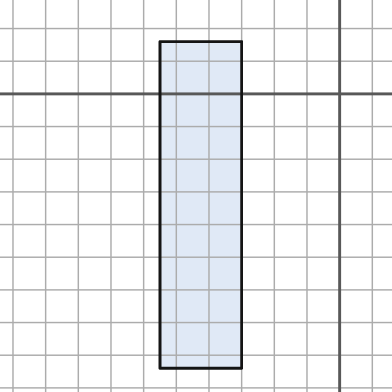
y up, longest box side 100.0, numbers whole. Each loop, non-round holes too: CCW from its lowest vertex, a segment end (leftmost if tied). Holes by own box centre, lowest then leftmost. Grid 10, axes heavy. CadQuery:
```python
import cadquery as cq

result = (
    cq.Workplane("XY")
    .moveTo(-55.0, -84.0)
    .lineTo(-30.0, -84.0)
    .lineTo(-30.0, 16.0)
    .lineTo(-55.0, 16.0)
    .close()
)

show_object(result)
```